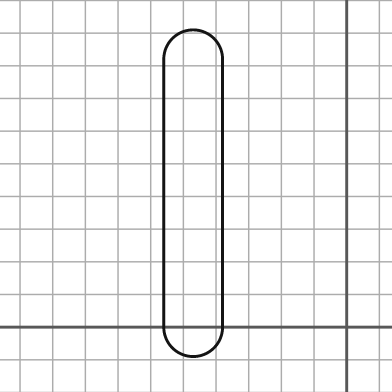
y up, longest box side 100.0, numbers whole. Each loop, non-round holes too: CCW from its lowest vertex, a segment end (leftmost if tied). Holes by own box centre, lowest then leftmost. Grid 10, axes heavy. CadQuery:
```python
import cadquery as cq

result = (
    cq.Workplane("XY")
    .moveTo(-56.0, 0.0)
    .threePointArc((-47.0, -9.0), (-38.0, 0.0))
    .lineTo(-38.0, 82.0)
    .threePointArc((-47.0, 91.0), (-56.0, 82.0))
    .close()
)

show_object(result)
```